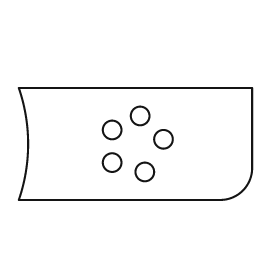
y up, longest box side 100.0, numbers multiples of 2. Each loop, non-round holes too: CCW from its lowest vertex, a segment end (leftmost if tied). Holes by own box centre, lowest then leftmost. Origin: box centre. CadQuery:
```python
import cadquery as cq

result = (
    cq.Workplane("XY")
    .moveTo(-50.0, -24.0)
    .lineTo(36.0, -24.0)
    .threePointArc((46.0, -20.0), (50.0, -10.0))
    .lineTo(50.0, 24.0)
    .lineTo(-50.0, 24.0)
    .threePointArc((-46.0, 0.0), (-50.0, -24.0))
    .close()
    .moveTo(4.0, -12.0)
    .circle(4.0)
    .moveTo(-10.0, -8.0)
    .circle(4.0)
    .moveTo(12.0, 2.0)
    .circle(4.0)
    .moveTo(-10.0, 6.0)
    .circle(4.0)
    .moveTo(2.0, 12.0)
    .circle(4.0)
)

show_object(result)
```